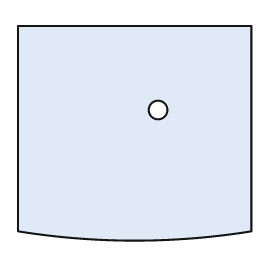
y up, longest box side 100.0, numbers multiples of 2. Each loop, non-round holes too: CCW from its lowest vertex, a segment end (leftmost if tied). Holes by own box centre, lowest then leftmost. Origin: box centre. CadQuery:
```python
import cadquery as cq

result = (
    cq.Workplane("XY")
    .moveTo(-50.0, -42.0)
    .threePointArc((0.0, -46.0), (50.0, -42.0))
    .lineTo(50.0, 46.0)
    .lineTo(-50.0, 46.0)
    .close()
    .moveTo(10.0, 10.0)
    .circle(4.0)
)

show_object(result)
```